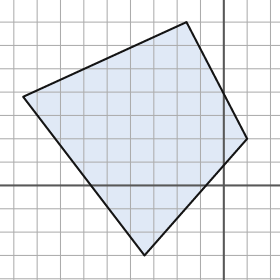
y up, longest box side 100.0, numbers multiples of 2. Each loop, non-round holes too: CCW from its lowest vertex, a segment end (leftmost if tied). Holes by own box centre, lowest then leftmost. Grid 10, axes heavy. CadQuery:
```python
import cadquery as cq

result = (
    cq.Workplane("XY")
    .moveTo(-34.0, -30.0)
    .lineTo(10.0, 20.0)
    .lineTo(-16.0, 70.0)
    .lineTo(-86.0, 38.0)
    .close()
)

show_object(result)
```